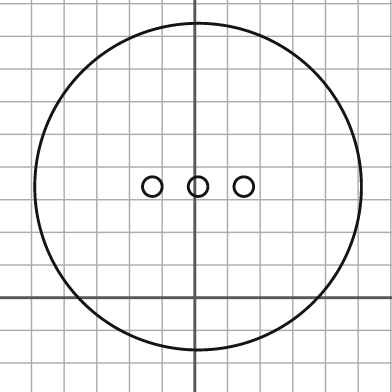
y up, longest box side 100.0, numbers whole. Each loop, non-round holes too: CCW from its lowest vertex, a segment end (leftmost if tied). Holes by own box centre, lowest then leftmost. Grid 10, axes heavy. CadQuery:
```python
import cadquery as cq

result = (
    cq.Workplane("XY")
    .moveTo(1.0, 34.0)
    .circle(50.0)
    .moveTo(-13.0, 34.0)
    .circle(3.0)
    .moveTo(1.0, 34.0)
    .circle(3.0)
    .moveTo(15.0, 34.0)
    .circle(3.0)
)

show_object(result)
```